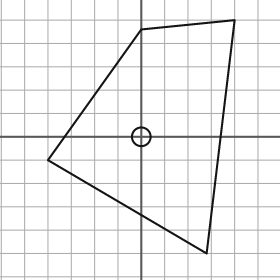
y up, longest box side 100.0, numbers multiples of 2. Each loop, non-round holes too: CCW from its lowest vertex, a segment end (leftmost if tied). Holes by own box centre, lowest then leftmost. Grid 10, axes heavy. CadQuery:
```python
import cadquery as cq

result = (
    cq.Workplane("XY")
    .moveTo(28.0, -50.0)
    .lineTo(40.0, 50.0)
    .lineTo(0.0, 46.0)
    .lineTo(-40.0, -10.0)
    .close()
    .moveTo(0.0, 0.0)
    .circle(4.0)
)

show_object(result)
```